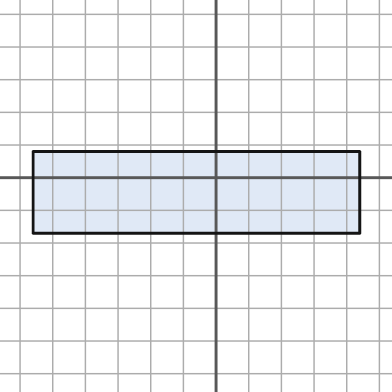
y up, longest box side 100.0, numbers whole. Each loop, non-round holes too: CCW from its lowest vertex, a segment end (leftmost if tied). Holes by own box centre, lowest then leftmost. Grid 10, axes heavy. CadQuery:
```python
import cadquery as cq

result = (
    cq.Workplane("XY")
    .moveTo(-56.0, -17.0)
    .lineTo(44.0, -17.0)
    .lineTo(44.0, 8.0)
    .lineTo(-56.0, 8.0)
    .close()
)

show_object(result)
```